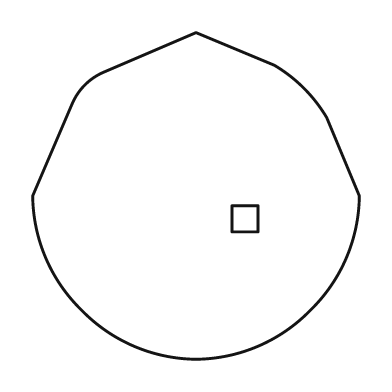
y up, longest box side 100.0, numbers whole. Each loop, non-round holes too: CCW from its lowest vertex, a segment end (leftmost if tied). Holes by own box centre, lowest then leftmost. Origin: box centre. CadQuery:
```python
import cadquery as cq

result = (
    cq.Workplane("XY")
    .moveTo(0.0, -50.0)
    .threePointArc((19.0, -46.0), (35.0, -35.0))
    .threePointArc((46.0, -19.0), (50.0, 0.0))
    .lineTo(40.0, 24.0)
    .threePointArc((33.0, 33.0), (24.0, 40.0))
    .lineTo(0.0, 50.0)
    .lineTo(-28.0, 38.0)
    .threePointArc((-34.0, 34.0), (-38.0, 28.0))
    .lineTo(-50.0, 0.0)
    .threePointArc((-46.0, -19.0), (-35.0, -35.0))
    .threePointArc((-19.0, -46.0), (0.0, -50.0))
    .close()
    .moveTo(11.0, -11.0)
    .lineTo(19.0, -11.0)
    .lineTo(19.0, -3.0)
    .lineTo(11.0, -3.0)
    .close()
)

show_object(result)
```